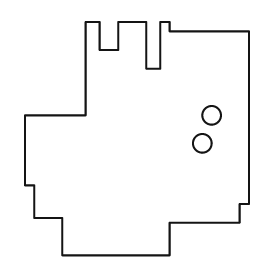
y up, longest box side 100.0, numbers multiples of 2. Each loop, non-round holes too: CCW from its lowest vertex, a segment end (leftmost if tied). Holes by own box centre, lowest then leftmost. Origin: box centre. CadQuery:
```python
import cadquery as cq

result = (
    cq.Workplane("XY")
    .moveTo(-32.0, -50.0)
    .lineTo(14.0, -50.0)
    .lineTo(14.0, -36.0)
    .lineTo(44.0, -36.0)
    .lineTo(44.0, -28.0)
    .lineTo(48.0, -28.0)
    .lineTo(48.0, 46.0)
    .lineTo(14.0, 46.0)
    .lineTo(14.0, 50.0)
    .lineTo(10.0, 50.0)
    .lineTo(10.0, 30.0)
    .lineTo(4.0, 30.0)
    .lineTo(4.0, 50.0)
    .lineTo(-8.0, 50.0)
    .lineTo(-8.0, 38.0)
    .lineTo(-16.0, 38.0)
    .lineTo(-16.0, 50.0)
    .lineTo(-22.0, 50.0)
    .lineTo(-22.0, 10.0)
    .lineTo(-48.0, 10.0)
    .lineTo(-48.0, -20.0)
    .lineTo(-44.0, -20.0)
    .lineTo(-44.0, -34.0)
    .lineTo(-32.0, -34.0)
    .close()
    .moveTo(28.0, -2.0)
    .circle(4.0)
    .moveTo(32.0, 10.0)
    .circle(4.0)
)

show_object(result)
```